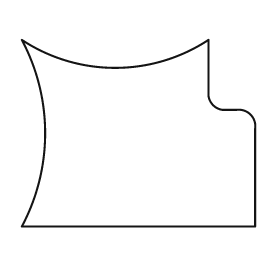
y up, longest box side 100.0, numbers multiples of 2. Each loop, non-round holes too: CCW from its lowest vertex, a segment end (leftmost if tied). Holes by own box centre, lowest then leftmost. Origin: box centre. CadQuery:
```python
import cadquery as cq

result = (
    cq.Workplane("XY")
    .moveTo(-50.0, -40.0)
    .lineTo(50.0, -40.0)
    .lineTo(50.0, 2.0)
    .threePointArc((48.0, 8.0), (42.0, 10.0))
    .lineTo(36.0, 10.0)
    .threePointArc((32.0, 12.0), (30.0, 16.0))
    .lineTo(30.0, 40.0)
    .threePointArc((-10.0, 28.0), (-50.0, 40.0))
    .threePointArc((-40.0, 0.0), (-50.0, -40.0))
    .close()
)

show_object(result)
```